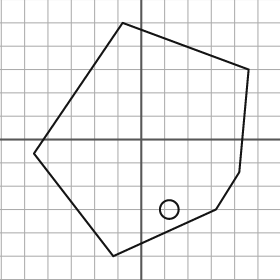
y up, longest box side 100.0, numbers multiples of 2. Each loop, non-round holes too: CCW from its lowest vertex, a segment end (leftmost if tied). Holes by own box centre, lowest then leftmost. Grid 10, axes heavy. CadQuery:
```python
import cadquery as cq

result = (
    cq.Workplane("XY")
    .moveTo(-12.0, -50.0)
    .lineTo(32.0, -30.0)
    .lineTo(42.0, -14.0)
    .lineTo(46.0, 30.0)
    .lineTo(-8.0, 50.0)
    .lineTo(-46.0, -6.0)
    .close()
    .moveTo(12.0, -30.0)
    .circle(4.0)
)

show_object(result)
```